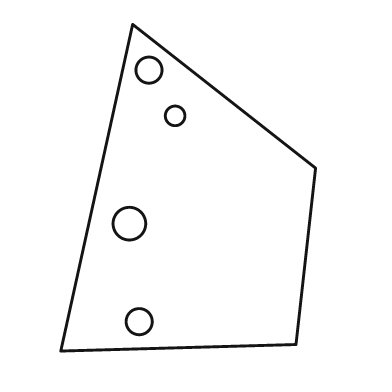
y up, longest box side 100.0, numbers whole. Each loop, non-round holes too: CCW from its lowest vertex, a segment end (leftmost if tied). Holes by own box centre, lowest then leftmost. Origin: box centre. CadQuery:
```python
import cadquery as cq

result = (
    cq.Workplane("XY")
    .moveTo(-39.0, -50.0)
    .lineTo(33.0, -48.0)
    .lineTo(39.0, 6.0)
    .lineTo(-17.0, 50.0)
    .close()
    .moveTo(-15.0, -41.0)
    .circle(4.0)
    .moveTo(-18.0, -11.0)
    .circle(5.0)
    .moveTo(-4.0, 22.0)
    .circle(3.0)
    .moveTo(-12.0, 36.0)
    .circle(4.0)
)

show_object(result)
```